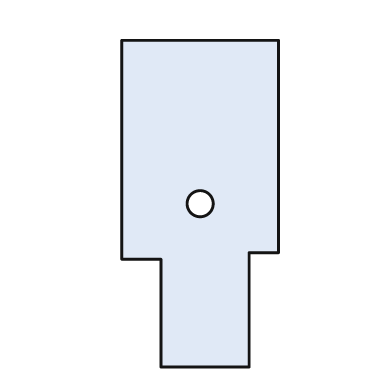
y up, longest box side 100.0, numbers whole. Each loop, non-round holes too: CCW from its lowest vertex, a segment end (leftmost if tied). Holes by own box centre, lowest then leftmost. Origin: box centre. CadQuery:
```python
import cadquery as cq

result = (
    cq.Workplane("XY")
    .moveTo(-12.0, -50.0)
    .lineTo(15.0, -50.0)
    .lineTo(15.0, -15.0)
    .lineTo(24.0, -15.0)
    .lineTo(24.0, 50.0)
    .lineTo(-24.0, 50.0)
    .lineTo(-24.0, -17.0)
    .lineTo(-12.0, -17.0)
    .close()
    .moveTo(0.0, 0.0)
    .circle(4.0)
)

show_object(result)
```